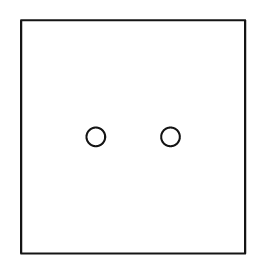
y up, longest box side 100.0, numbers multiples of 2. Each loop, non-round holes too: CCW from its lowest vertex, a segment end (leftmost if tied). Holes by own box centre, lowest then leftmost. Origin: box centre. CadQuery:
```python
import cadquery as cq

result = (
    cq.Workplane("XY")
    .moveTo(-48.0, -50.0)
    .lineTo(48.0, -50.0)
    .lineTo(48.0, 50.0)
    .lineTo(-48.0, 50.0)
    .close()
    .moveTo(-16.0, 0.0)
    .circle(4.0)
    .moveTo(16.0, 0.0)
    .circle(4.0)
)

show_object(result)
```